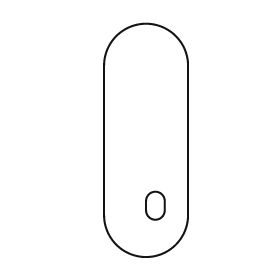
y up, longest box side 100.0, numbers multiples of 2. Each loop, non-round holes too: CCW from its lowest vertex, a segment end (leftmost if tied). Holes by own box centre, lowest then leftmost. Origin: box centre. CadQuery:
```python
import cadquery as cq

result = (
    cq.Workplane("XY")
    .moveTo(-18.0, -32.0)
    .threePointArc((0.0, -50.0), (18.0, -32.0))
    .lineTo(18.0, 32.0)
    .threePointArc((0.0, 50.0), (-18.0, 32.0))
    .close()
    .moveTo(0.0, -30.0)
    .threePointArc((4.0, -34.0), (8.0, -30.0))
    .lineTo(8.0, -26.0)
    .threePointArc((4.0, -22.0), (0.0, -26.0))
    .close()
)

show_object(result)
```